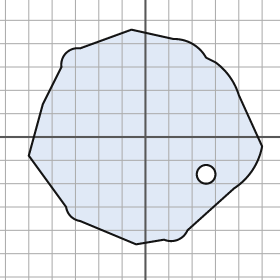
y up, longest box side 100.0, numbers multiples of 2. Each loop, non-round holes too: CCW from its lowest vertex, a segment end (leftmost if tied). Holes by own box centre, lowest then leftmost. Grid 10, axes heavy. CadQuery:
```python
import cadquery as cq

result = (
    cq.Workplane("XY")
    .moveTo(-4.0, -46.0)
    .lineTo(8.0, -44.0)
    .threePointArc((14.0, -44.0), (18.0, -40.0))
    .lineTo(38.0, -22.0)
    .threePointArc((46.0, -14.0), (50.0, -4.0))
    .lineTo(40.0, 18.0)
    .threePointArc((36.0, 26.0), (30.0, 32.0))
    .lineTo(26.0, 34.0)
    .threePointArc((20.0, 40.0), (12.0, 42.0))
    .lineTo(-6.0, 46.0)
    .lineTo(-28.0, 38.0)
    .threePointArc((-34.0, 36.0), (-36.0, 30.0))
    .lineTo(-44.0, 14.0)
    .lineTo(-50.0, -8.0)
    .lineTo(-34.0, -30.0)
    .threePointArc((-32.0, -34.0), (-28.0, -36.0))
    .close()
    .moveTo(26.0, -16.0)
    .circle(4.0)
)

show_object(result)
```